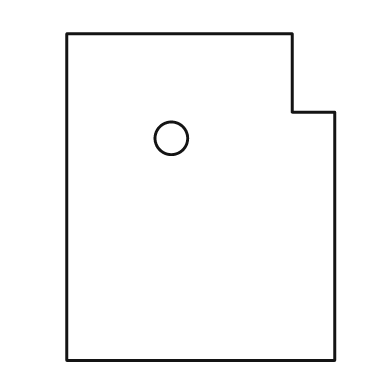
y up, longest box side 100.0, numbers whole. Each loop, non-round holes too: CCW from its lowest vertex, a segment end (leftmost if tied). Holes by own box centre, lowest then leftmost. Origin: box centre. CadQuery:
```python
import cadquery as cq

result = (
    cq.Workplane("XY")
    .moveTo(-41.0, -50.0)
    .lineTo(41.0, -50.0)
    .lineTo(41.0, 26.0)
    .lineTo(28.0, 26.0)
    .lineTo(28.0, 50.0)
    .lineTo(-41.0, 50.0)
    .close()
    .moveTo(-9.0, 18.0)
    .circle(5.0)
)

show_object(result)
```